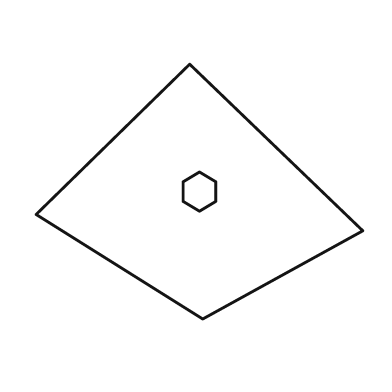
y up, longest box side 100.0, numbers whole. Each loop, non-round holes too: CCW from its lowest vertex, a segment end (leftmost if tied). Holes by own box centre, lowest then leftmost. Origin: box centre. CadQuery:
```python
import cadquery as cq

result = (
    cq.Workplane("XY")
    .moveTo(1.0, -39.0)
    .lineTo(50.0, -12.0)
    .lineTo(-3.0, 39.0)
    .lineTo(-50.0, -7.0)
    .close()
    .moveTo(0.0, -6.0)
    .lineTo(5.0, -3.0)
    .lineTo(5.0, 3.0)
    .lineTo(0.0, 6.0)
    .lineTo(-5.0, 3.0)
    .lineTo(-5.0, -3.0)
    .close()
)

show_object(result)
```